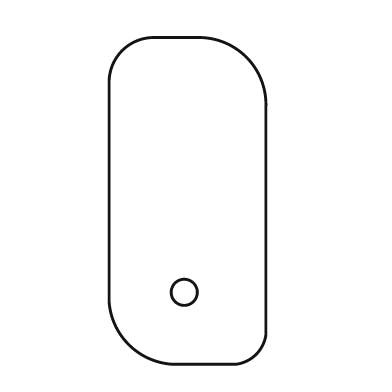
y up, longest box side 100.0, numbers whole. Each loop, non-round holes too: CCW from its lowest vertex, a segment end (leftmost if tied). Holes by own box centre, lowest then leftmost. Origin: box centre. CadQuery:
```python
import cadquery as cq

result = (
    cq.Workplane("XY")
    .moveTo(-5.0, -50.0)
    .lineTo(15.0, -50.0)
    .threePointArc((21.0, -47.0), (24.0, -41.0))
    .lineTo(24.0, 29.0)
    .threePointArc((18.0, 44.0), (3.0, 50.0))
    .lineTo(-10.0, 50.0)
    .threePointArc((-20.0, 46.0), (-24.0, 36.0))
    .lineTo(-24.0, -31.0)
    .threePointArc((-18.0, -44.0), (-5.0, -50.0))
    .close()
    .moveTo(-1.0, -28.0)
    .circle(4.0)
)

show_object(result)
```